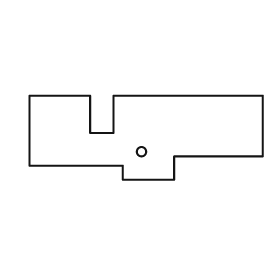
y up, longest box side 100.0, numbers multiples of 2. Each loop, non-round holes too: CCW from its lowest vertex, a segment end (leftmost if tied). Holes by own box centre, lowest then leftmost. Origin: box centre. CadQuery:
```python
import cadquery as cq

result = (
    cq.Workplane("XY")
    .moveTo(-10.0, -18.0)
    .lineTo(12.0, -18.0)
    .lineTo(12.0, -8.0)
    .lineTo(50.0, -8.0)
    .lineTo(50.0, 18.0)
    .lineTo(-14.0, 18.0)
    .lineTo(-14.0, 2.0)
    .lineTo(-24.0, 2.0)
    .lineTo(-24.0, 18.0)
    .lineTo(-50.0, 18.0)
    .lineTo(-50.0, -12.0)
    .lineTo(-10.0, -12.0)
    .close()
    .moveTo(-2.0, -6.0)
    .circle(2.0)
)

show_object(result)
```